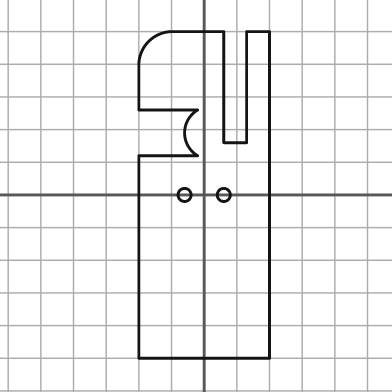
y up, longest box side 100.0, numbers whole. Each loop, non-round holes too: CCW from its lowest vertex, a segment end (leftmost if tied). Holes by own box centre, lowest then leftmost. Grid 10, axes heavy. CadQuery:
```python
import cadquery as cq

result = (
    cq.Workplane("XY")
    .moveTo(-20.0, -50.0)
    .lineTo(20.0, -50.0)
    .lineTo(20.0, 50.0)
    .lineTo(13.0, 50.0)
    .lineTo(13.0, 16.0)
    .lineTo(6.0, 16.0)
    .lineTo(6.0, 50.0)
    .lineTo(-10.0, 50.0)
    .threePointArc((-17.0, 47.0), (-20.0, 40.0))
    .lineTo(-20.0, 26.0)
    .lineTo(-2.0, 26.0)
    .threePointArc((-6.0, 19.0), (-2.0, 12.0))
    .lineTo(-20.0, 12.0)
    .close()
    .moveTo(-6.0, 0.0)
    .circle(2.0)
    .moveTo(6.0, 0.0)
    .circle(2.0)
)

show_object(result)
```